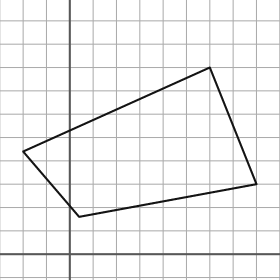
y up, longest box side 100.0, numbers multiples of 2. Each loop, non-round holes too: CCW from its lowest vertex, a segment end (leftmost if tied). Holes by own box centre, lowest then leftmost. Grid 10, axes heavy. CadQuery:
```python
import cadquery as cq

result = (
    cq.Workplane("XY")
    .moveTo(4.0, 16.0)
    .lineTo(80.0, 30.0)
    .lineTo(60.0, 80.0)
    .lineTo(-20.0, 44.0)
    .close()
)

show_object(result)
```